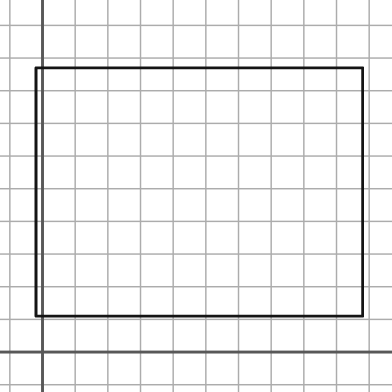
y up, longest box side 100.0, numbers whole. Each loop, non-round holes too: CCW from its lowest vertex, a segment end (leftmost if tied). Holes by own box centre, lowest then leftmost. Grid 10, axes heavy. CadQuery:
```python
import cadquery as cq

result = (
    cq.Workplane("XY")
    .moveTo(-2.0, 11.0)
    .lineTo(98.0, 11.0)
    .lineTo(98.0, 87.0)
    .lineTo(-2.0, 87.0)
    .close()
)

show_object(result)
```